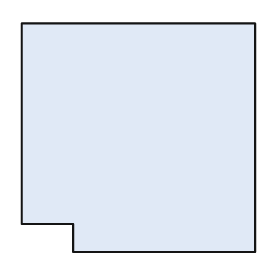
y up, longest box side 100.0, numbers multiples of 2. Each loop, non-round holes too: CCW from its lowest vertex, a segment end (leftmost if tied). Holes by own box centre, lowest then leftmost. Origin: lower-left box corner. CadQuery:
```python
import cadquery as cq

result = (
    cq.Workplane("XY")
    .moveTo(22.0, 0.0)
    .lineTo(100.0, 0.0)
    .lineTo(100.0, 98.0)
    .lineTo(0.0, 98.0)
    .lineTo(0.0, 12.0)
    .lineTo(22.0, 12.0)
    .close()
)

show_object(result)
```